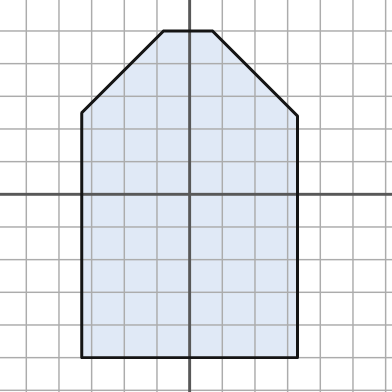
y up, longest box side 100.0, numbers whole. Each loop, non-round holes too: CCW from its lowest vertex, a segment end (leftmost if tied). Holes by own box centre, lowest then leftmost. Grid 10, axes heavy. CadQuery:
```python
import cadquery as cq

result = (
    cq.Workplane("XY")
    .moveTo(-33.0, -50.0)
    .lineTo(33.0, -50.0)
    .lineTo(33.0, 24.0)
    .lineTo(7.0, 50.0)
    .lineTo(-8.0, 50.0)
    .lineTo(-33.0, 25.0)
    .close()
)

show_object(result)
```